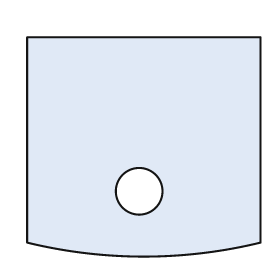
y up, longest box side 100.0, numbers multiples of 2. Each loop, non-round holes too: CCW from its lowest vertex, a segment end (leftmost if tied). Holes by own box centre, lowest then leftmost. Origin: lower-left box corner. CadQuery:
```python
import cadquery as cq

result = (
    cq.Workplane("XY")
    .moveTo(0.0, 6.0)
    .threePointArc((50.0, 0.0), (100.0, 6.0))
    .lineTo(100.0, 94.0)
    .lineTo(0.0, 94.0)
    .close()
    .moveTo(48.0, 28.0)
    .circle(10.0)
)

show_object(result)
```